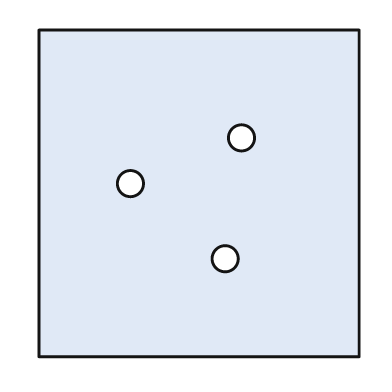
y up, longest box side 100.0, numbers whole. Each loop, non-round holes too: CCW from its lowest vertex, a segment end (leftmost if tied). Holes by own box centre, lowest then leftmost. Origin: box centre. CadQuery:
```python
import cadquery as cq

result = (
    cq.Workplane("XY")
    .moveTo(-49.0, -50.0)
    .lineTo(49.0, -50.0)
    .lineTo(49.0, 50.0)
    .lineTo(-49.0, 50.0)
    .close()
    .moveTo(8.0, -20.0)
    .circle(4.0)
    .moveTo(-21.0, 3.0)
    .circle(4.0)
    .moveTo(13.0, 17.0)
    .circle(4.0)
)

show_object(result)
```